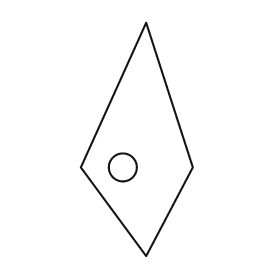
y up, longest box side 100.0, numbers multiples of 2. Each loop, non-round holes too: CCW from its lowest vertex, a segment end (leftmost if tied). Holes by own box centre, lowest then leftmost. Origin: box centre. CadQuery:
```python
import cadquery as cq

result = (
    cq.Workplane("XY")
    .moveTo(4.0, -50.0)
    .lineTo(24.0, -12.0)
    .lineTo(4.0, 50.0)
    .lineTo(-24.0, -12.0)
    .close()
    .moveTo(-6.0, -12.0)
    .circle(6.0)
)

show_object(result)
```